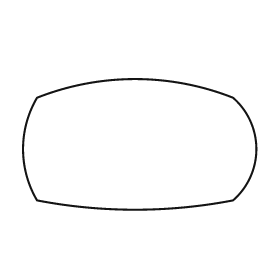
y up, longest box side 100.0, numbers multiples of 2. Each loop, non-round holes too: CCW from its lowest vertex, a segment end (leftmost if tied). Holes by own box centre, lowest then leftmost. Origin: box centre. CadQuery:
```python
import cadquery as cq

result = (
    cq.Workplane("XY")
    .moveTo(-44.0, -24.0)
    .threePointArc((-2.0, -28.0), (40.0, -24.0))
    .threePointArc((50.0, -2.0), (40.0, 20.0))
    .threePointArc((-2.0, 28.0), (-44.0, 20.0))
    .threePointArc((-50.0, -2.0), (-44.0, -24.0))
    .close()
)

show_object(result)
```